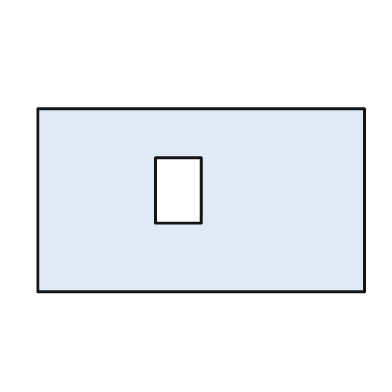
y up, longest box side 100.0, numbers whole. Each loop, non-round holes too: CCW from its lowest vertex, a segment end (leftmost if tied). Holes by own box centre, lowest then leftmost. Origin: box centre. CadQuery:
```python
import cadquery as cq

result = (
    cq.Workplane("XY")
    .moveTo(-50.0, -28.0)
    .lineTo(50.0, -28.0)
    .lineTo(50.0, 28.0)
    .lineTo(-50.0, 28.0)
    .close()
    .moveTo(-14.0, -7.0)
    .lineTo(0.0, -7.0)
    .lineTo(0.0, 13.0)
    .lineTo(-14.0, 13.0)
    .close()
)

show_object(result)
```